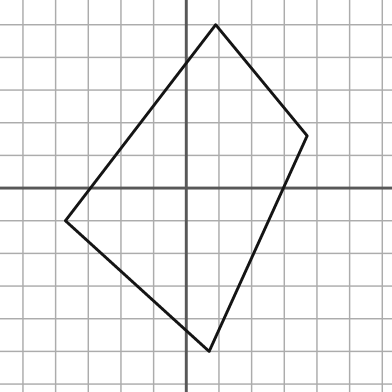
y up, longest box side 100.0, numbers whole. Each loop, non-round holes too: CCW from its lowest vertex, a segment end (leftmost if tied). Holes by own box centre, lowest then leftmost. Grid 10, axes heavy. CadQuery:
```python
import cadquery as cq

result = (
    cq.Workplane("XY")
    .moveTo(7.0, -50.0)
    .lineTo(37.0, 16.0)
    .lineTo(9.0, 50.0)
    .lineTo(-37.0, -10.0)
    .close()
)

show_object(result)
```